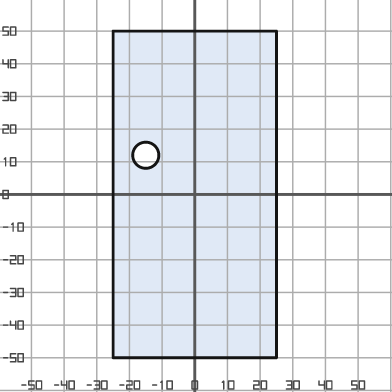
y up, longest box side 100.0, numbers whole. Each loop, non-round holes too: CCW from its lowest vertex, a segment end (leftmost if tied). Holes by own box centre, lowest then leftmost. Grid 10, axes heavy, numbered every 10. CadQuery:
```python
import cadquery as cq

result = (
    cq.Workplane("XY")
    .moveTo(-25.0, -50.0)
    .lineTo(25.0, -50.0)
    .lineTo(25.0, 50.0)
    .lineTo(-25.0, 50.0)
    .close()
    .moveTo(-15.0, 12.0)
    .circle(4.0)
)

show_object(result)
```